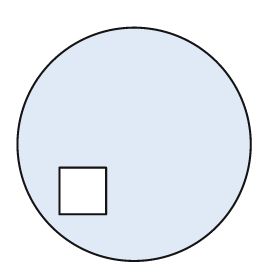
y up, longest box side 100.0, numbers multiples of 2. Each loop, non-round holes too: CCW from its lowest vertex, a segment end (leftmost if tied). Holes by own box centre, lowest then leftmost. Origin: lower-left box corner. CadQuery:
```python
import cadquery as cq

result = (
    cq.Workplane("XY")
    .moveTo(50.0, 50.0)
    .circle(50.0)
    .moveTo(18.0, 20.0)
    .lineTo(38.0, 20.0)
    .lineTo(38.0, 40.0)
    .lineTo(18.0, 40.0)
    .close()
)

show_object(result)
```